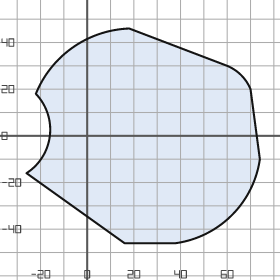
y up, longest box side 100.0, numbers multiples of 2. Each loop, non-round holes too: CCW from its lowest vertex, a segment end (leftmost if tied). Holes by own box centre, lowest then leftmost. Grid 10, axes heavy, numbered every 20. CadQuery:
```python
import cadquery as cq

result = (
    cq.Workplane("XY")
    .moveTo(16.0, -46.0)
    .lineTo(38.0, -46.0)
    .threePointArc((62.0, -34.0), (74.0, -10.0))
    .lineTo(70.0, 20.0)
    .threePointArc((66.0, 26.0), (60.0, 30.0))
    .lineTo(18.0, 46.0)
    .threePointArc((-6.0, 38.0), (-22.0, 18.0))
    .threePointArc((-16.0, 0.0), (-26.0, -16.0))
    .close()
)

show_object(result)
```